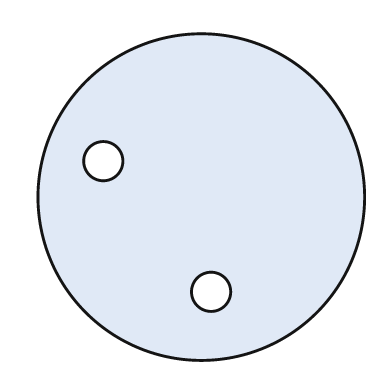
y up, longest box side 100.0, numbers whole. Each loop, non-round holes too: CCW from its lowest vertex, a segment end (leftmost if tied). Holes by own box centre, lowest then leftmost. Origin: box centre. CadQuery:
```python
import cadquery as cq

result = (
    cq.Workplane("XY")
    .moveTo(0.0, 0.0)
    .circle(50.0)
    .moveTo(3.0, -29.0)
    .circle(6.0)
    .moveTo(-30.0, 11.0)
    .circle(6.0)
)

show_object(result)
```